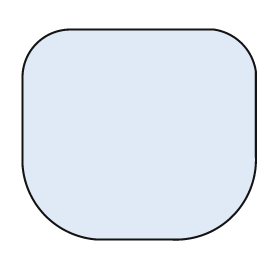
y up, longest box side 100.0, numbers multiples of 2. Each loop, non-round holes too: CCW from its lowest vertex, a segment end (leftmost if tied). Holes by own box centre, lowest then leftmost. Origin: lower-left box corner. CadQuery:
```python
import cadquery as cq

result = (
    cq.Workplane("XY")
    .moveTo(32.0, 0.0)
    .lineTo(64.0, 0.0)
    .threePointArc((90.0, 10.0), (100.0, 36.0))
    .lineTo(100.0, 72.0)
    .threePointArc((94.0, 84.0), (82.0, 90.0))
    .lineTo(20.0, 90.0)
    .threePointArc((6.0, 84.0), (0.0, 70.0))
    .lineTo(0.0, 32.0)
    .threePointArc((10.0, 10.0), (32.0, 0.0))
    .close()
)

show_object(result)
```